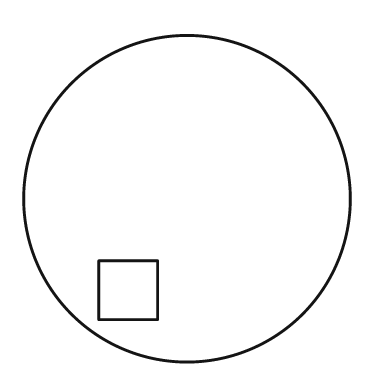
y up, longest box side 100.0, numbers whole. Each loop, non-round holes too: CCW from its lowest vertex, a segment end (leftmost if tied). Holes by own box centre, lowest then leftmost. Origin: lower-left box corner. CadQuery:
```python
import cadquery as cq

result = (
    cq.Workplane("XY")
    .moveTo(50.0, 50.0)
    .circle(50.0)
    .moveTo(23.0, 13.0)
    .lineTo(41.0, 13.0)
    .lineTo(41.0, 31.0)
    .lineTo(23.0, 31.0)
    .close()
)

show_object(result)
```